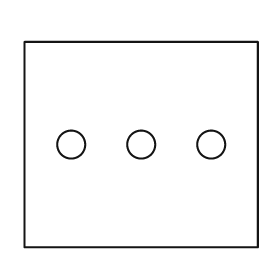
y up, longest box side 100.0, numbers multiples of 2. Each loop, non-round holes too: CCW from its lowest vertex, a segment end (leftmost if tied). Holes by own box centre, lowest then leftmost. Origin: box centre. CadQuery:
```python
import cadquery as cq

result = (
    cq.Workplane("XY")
    .moveTo(-50.0, -44.0)
    .lineTo(50.0, -44.0)
    .lineTo(50.0, 44.0)
    .lineTo(-50.0, 44.0)
    .close()
    .moveTo(-30.0, 0.0)
    .circle(6.0)
    .moveTo(0.0, 0.0)
    .circle(6.0)
    .moveTo(30.0, 0.0)
    .circle(6.0)
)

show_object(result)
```